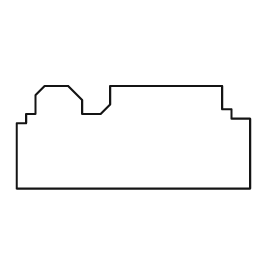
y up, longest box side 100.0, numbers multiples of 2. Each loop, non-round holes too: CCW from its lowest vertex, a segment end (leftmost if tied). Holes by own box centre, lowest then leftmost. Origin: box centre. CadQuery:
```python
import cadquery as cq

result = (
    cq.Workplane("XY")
    .moveTo(-50.0, -22.0)
    .lineTo(50.0, -22.0)
    .lineTo(50.0, 8.0)
    .lineTo(42.0, 8.0)
    .lineTo(42.0, 12.0)
    .lineTo(38.0, 12.0)
    .lineTo(38.0, 22.0)
    .lineTo(-10.0, 22.0)
    .lineTo(-10.0, 14.0)
    .lineTo(-14.0, 10.0)
    .lineTo(-22.0, 10.0)
    .lineTo(-22.0, 16.0)
    .lineTo(-28.0, 22.0)
    .lineTo(-38.0, 22.0)
    .lineTo(-42.0, 18.0)
    .lineTo(-42.0, 10.0)
    .lineTo(-46.0, 10.0)
    .lineTo(-46.0, 6.0)
    .lineTo(-50.0, 6.0)
    .close()
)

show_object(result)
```